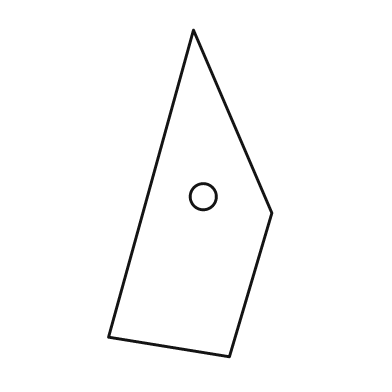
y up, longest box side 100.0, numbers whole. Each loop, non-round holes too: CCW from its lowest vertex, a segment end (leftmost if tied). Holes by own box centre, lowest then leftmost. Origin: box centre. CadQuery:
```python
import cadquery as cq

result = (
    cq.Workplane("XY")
    .moveTo(12.0, -50.0)
    .lineTo(25.0, -6.0)
    .lineTo(1.0, 50.0)
    .lineTo(-25.0, -44.0)
    .close()
    .moveTo(4.0, -1.0)
    .circle(4.0)
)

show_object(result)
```